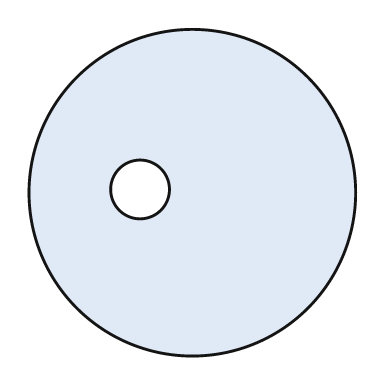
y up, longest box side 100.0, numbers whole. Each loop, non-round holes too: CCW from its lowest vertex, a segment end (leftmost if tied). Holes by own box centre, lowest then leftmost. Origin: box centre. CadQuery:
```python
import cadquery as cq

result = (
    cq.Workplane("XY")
    .moveTo(0.0, 0.0)
    .circle(50.0)
    .moveTo(-16.0, 1.0)
    .circle(9.0)
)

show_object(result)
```